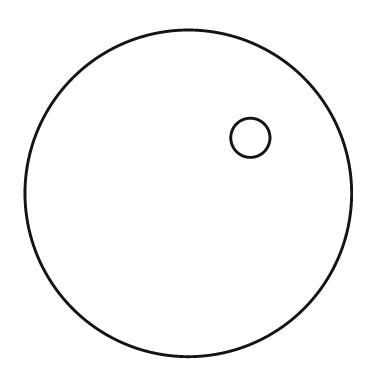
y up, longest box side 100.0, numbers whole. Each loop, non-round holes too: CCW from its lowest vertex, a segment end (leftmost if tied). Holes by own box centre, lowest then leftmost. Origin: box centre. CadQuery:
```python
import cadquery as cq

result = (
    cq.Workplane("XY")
    .moveTo(0.0, 0.0)
    .circle(50.0)
    .moveTo(19.0, 17.0)
    .circle(6.0)
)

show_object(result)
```